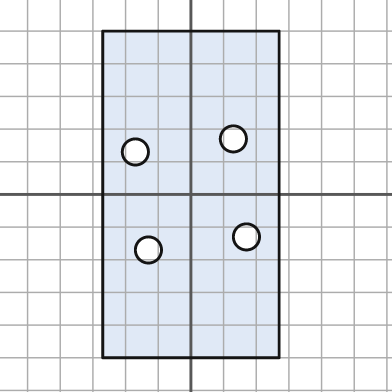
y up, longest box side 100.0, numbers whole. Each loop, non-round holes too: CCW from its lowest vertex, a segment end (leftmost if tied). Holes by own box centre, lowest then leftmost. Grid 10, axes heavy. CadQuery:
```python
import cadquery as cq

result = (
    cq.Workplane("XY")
    .moveTo(-27.0, -50.0)
    .lineTo(27.0, -50.0)
    .lineTo(27.0, 50.0)
    .lineTo(-27.0, 50.0)
    .close()
    .moveTo(-13.0, -17.0)
    .circle(4.0)
    .moveTo(17.0, -13.0)
    .circle(4.0)
    .moveTo(-17.0, 13.0)
    .circle(4.0)
    .moveTo(13.0, 17.0)
    .circle(4.0)
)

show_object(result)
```